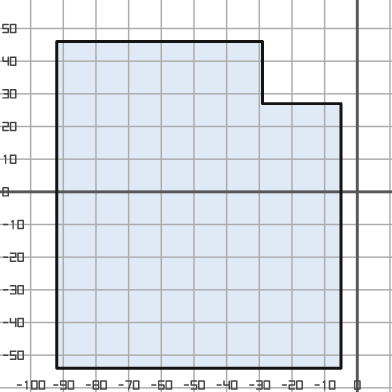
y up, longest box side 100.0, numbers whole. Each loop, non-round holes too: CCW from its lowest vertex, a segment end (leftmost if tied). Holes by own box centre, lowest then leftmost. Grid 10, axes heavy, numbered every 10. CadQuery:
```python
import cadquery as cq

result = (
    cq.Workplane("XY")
    .moveTo(-92.0, -54.0)
    .lineTo(-5.0, -54.0)
    .lineTo(-5.0, 27.0)
    .lineTo(-29.0, 27.0)
    .lineTo(-29.0, 46.0)
    .lineTo(-92.0, 46.0)
    .close()
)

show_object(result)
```